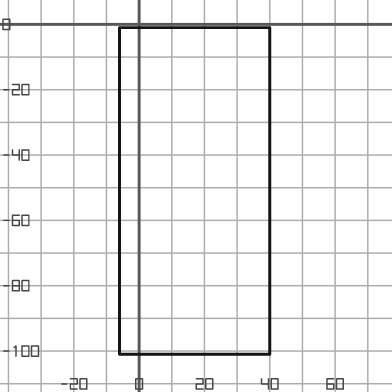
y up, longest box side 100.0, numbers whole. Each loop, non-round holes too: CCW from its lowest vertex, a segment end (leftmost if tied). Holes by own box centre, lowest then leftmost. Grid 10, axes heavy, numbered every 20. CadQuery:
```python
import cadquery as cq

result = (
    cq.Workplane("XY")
    .moveTo(-6.0, -101.0)
    .lineTo(40.0, -101.0)
    .lineTo(40.0, -1.0)
    .lineTo(-6.0, -1.0)
    .close()
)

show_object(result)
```